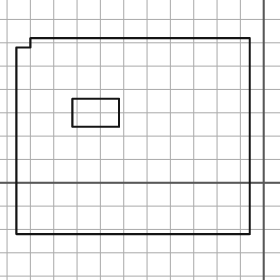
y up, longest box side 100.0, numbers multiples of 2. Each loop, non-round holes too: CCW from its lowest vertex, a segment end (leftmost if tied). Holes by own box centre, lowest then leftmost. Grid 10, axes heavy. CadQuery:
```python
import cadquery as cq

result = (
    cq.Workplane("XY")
    .moveTo(-106.0, -22.0)
    .lineTo(-6.0, -22.0)
    .lineTo(-6.0, 62.0)
    .lineTo(-100.0, 62.0)
    .lineTo(-100.0, 58.0)
    .lineTo(-106.0, 58.0)
    .close()
    .moveTo(-82.0, 24.0)
    .lineTo(-62.0, 24.0)
    .lineTo(-62.0, 36.0)
    .lineTo(-82.0, 36.0)
    .close()
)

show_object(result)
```